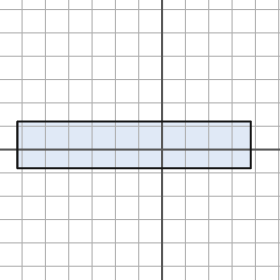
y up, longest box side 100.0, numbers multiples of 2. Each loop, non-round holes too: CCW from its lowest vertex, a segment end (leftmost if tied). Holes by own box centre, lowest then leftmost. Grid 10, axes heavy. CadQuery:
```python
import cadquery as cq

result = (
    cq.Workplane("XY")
    .moveTo(-62.0, -8.0)
    .lineTo(38.0, -8.0)
    .lineTo(38.0, 12.0)
    .lineTo(-62.0, 12.0)
    .close()
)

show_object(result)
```